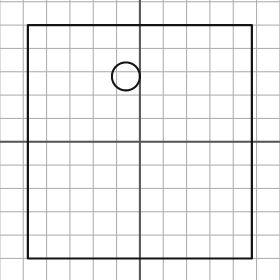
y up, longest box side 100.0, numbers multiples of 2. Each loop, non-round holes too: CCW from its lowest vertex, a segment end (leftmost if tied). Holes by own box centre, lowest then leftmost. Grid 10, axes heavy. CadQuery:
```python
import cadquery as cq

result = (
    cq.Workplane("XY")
    .moveTo(-48.0, -50.0)
    .lineTo(48.0, -50.0)
    .lineTo(48.0, 50.0)
    .lineTo(-48.0, 50.0)
    .close()
    .moveTo(-6.0, 28.0)
    .circle(6.0)
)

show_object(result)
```